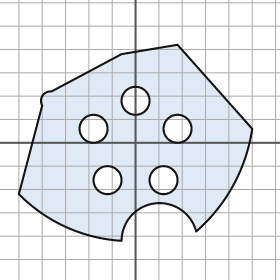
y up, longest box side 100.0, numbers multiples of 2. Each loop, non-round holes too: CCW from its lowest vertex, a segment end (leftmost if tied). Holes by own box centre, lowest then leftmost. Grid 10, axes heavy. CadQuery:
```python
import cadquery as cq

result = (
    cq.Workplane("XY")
    .moveTo(-6.0, -42.0)
    .threePointArc((8.0, -26.0), (26.0, -38.0))
    .threePointArc((42.0, -18.0), (50.0, 6.0))
    .lineTo(18.0, 42.0)
    .lineTo(-6.0, 38.0)
    .lineTo(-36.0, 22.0)
    .threePointArc((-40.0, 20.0), (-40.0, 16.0))
    .lineTo(-50.0, -22.0)
    .threePointArc((-30.0, -36.0), (-6.0, -42.0))
    .close()
    .moveTo(-12.0, -16.0)
    .circle(6.0)
    .moveTo(12.0, -16.0)
    .circle(6.0)
    .moveTo(-18.0, 6.0)
    .circle(6.0)
    .moveTo(18.0, 6.0)
    .circle(6.0)
    .moveTo(0.0, 18.0)
    .circle(6.0)
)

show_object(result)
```